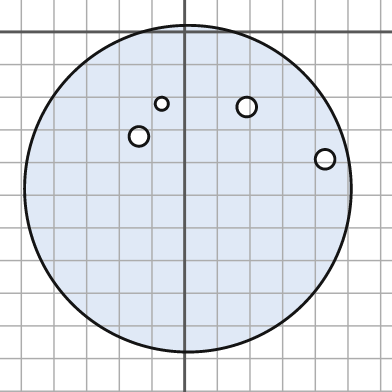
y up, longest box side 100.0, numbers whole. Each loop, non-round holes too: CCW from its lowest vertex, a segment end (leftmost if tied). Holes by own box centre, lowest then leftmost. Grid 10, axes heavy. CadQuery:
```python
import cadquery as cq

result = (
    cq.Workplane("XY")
    .moveTo(1.0, -48.0)
    .circle(50.0)
    .moveTo(43.0, -39.0)
    .circle(3.0)
    .moveTo(-14.0, -32.0)
    .circle(3.0)
    .moveTo(19.0, -23.0)
    .circle(3.0)
    .moveTo(-7.0, -22.0)
    .circle(2.0)
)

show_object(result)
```